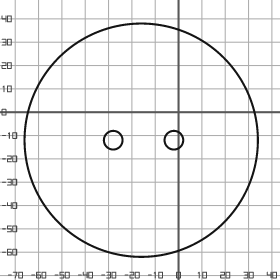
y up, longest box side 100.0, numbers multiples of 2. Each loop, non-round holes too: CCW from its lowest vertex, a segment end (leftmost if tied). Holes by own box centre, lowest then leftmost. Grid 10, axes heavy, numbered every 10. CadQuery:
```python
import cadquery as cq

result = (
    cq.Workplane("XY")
    .moveTo(-16.0, -12.0)
    .circle(50.0)
    .moveTo(-28.0, -12.0)
    .circle(4.0)
    .moveTo(-2.0, -12.0)
    .circle(4.0)
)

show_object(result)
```